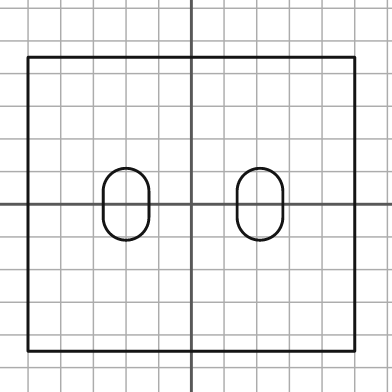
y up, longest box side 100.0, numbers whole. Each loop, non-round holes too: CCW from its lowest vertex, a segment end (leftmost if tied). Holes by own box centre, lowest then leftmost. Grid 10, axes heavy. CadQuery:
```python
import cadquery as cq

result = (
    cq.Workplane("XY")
    .moveTo(-50.0, -45.0)
    .lineTo(50.0, -45.0)
    .lineTo(50.0, 45.0)
    .lineTo(-50.0, 45.0)
    .close()
    .moveTo(-27.0, -4.0)
    .threePointArc((-20.0, -11.0), (-13.0, -4.0))
    .lineTo(-13.0, 4.0)
    .threePointArc((-20.0, 11.0), (-27.0, 4.0))
    .close()
    .moveTo(14.0, -4.0)
    .threePointArc((21.0, -11.0), (28.0, -4.0))
    .lineTo(28.0, 4.0)
    .threePointArc((21.0, 11.0), (14.0, 4.0))
    .close()
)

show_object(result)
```